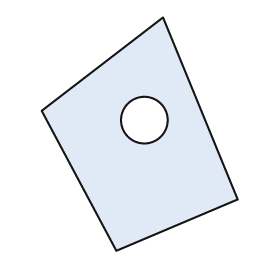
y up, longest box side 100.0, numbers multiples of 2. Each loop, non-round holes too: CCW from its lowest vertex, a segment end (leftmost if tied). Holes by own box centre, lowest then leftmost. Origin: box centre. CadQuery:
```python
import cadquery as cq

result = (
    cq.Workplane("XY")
    .moveTo(-10.0, -50.0)
    .lineTo(42.0, -28.0)
    .lineTo(10.0, 50.0)
    .lineTo(-42.0, 10.0)
    .close()
    .moveTo(2.0, 6.0)
    .circle(10.0)
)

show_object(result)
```